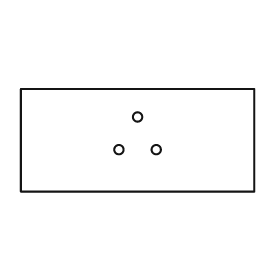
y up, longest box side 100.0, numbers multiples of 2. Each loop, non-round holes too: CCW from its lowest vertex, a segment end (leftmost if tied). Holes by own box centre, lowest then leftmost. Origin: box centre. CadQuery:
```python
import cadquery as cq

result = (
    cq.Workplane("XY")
    .moveTo(-50.0, -22.0)
    .lineTo(50.0, -22.0)
    .lineTo(50.0, 22.0)
    .lineTo(-50.0, 22.0)
    .close()
    .moveTo(-8.0, -4.0)
    .circle(2.0)
    .moveTo(8.0, -4.0)
    .circle(2.0)
    .moveTo(0.0, 10.0)
    .circle(2.0)
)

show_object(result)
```